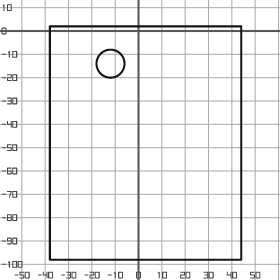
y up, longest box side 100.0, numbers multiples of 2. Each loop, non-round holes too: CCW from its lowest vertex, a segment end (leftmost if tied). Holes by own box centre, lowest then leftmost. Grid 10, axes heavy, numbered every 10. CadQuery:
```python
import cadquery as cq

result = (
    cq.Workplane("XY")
    .moveTo(-38.0, -98.0)
    .lineTo(44.0, -98.0)
    .lineTo(44.0, 2.0)
    .lineTo(-38.0, 2.0)
    .close()
    .moveTo(-12.0, -14.0)
    .circle(6.0)
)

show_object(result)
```